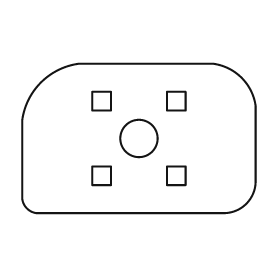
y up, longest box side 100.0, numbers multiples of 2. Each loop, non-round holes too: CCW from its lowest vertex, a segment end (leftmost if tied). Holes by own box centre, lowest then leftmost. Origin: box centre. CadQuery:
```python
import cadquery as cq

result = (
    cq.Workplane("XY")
    .moveTo(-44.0, -32.0)
    .lineTo(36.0, -32.0)
    .threePointArc((46.0, -28.0), (50.0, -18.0))
    .lineTo(50.0, 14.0)
    .threePointArc((44.0, 26.0), (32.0, 32.0))
    .lineTo(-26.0, 32.0)
    .threePointArc((-42.0, 24.0), (-50.0, 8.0))
    .lineTo(-50.0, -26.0)
    .threePointArc((-48.0, -30.0), (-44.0, -32.0))
    .close()
    .moveTo(-20.0, -20.0)
    .lineTo(-12.0, -20.0)
    .lineTo(-12.0, -12.0)
    .lineTo(-20.0, -12.0)
    .close()
    .moveTo(12.0, -20.0)
    .lineTo(20.0, -20.0)
    .lineTo(20.0, -12.0)
    .lineTo(12.0, -12.0)
    .close()
    .moveTo(0.0, 0.0)
    .circle(8.0)
    .moveTo(-20.0, 12.0)
    .lineTo(-12.0, 12.0)
    .lineTo(-12.0, 20.0)
    .lineTo(-20.0, 20.0)
    .close()
    .moveTo(12.0, 12.0)
    .lineTo(20.0, 12.0)
    .lineTo(20.0, 20.0)
    .lineTo(12.0, 20.0)
    .close()
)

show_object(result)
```